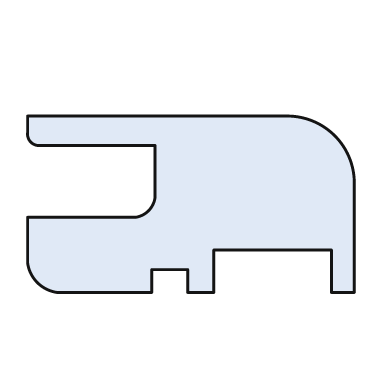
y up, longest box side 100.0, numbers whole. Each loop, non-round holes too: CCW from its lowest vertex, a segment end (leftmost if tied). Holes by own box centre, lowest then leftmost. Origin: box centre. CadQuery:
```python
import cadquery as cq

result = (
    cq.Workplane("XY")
    .moveTo(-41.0, -27.0)
    .lineTo(-12.0, -27.0)
    .lineTo(-12.0, -20.0)
    .lineTo(-1.0, -20.0)
    .lineTo(-1.0, -27.0)
    .lineTo(7.0, -27.0)
    .lineTo(7.0, -14.0)
    .lineTo(43.0, -14.0)
    .lineTo(43.0, -27.0)
    .lineTo(50.0, -27.0)
    .lineTo(50.0, 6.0)
    .threePointArc((44.0, 21.0), (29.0, 27.0))
    .lineTo(-50.0, 27.0)
    .lineTo(-50.0, 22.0)
    .threePointArc((-49.0, 19.0), (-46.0, 18.0))
    .lineTo(-11.0, 18.0)
    .lineTo(-11.0, 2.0)
    .threePointArc((-13.0, -2.0), (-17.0, -4.0))
    .lineTo(-50.0, -4.0)
    .lineTo(-50.0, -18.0)
    .threePointArc((-47.0, -24.0), (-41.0, -27.0))
    .close()
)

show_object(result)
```